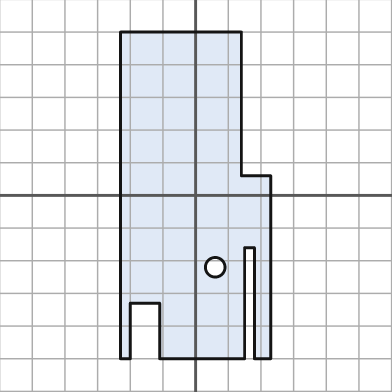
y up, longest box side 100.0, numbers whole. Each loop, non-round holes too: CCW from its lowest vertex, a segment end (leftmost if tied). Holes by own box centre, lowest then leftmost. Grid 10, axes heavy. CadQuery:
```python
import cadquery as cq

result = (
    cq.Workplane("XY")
    .moveTo(-23.0, -50.0)
    .lineTo(-20.0, -50.0)
    .lineTo(-20.0, -33.0)
    .lineTo(-11.0, -33.0)
    .lineTo(-11.0, -50.0)
    .lineTo(15.0, -50.0)
    .lineTo(15.0, -16.0)
    .lineTo(18.0, -16.0)
    .lineTo(18.0, -50.0)
    .lineTo(23.0, -50.0)
    .lineTo(23.0, 6.0)
    .lineTo(14.0, 6.0)
    .lineTo(14.0, 50.0)
    .lineTo(-23.0, 50.0)
    .close()
    .moveTo(6.0, -22.0)
    .circle(3.0)
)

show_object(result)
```